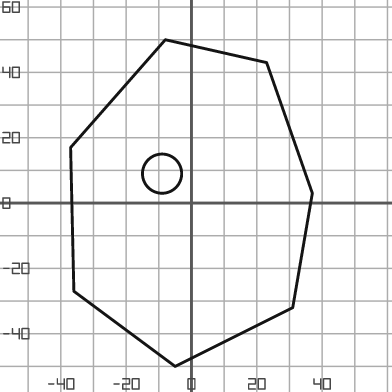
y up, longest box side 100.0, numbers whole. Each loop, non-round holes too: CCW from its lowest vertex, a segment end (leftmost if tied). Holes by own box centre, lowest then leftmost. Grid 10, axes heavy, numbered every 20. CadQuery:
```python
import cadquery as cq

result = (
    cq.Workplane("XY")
    .moveTo(-5.0, -50.0)
    .lineTo(31.0, -32.0)
    .lineTo(37.0, 3.0)
    .lineTo(23.0, 43.0)
    .lineTo(-8.0, 50.0)
    .lineTo(-37.0, 17.0)
    .lineTo(-36.0, -27.0)
    .close()
    .moveTo(-9.0, 9.0)
    .circle(6.0)
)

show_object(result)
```